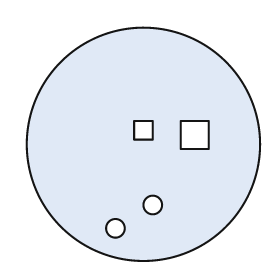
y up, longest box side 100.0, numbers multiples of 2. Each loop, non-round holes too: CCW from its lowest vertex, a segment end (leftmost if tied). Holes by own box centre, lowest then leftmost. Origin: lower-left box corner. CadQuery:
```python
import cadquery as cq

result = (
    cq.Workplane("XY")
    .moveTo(50.0, 50.0)
    .circle(50.0)
    .moveTo(38.0, 14.0)
    .circle(4.0)
    .moveTo(54.0, 24.0)
    .circle(4.0)
    .moveTo(66.0, 48.0)
    .lineTo(78.0, 48.0)
    .lineTo(78.0, 60.0)
    .lineTo(66.0, 60.0)
    .close()
    .moveTo(46.0, 52.0)
    .lineTo(54.0, 52.0)
    .lineTo(54.0, 60.0)
    .lineTo(46.0, 60.0)
    .close()
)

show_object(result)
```